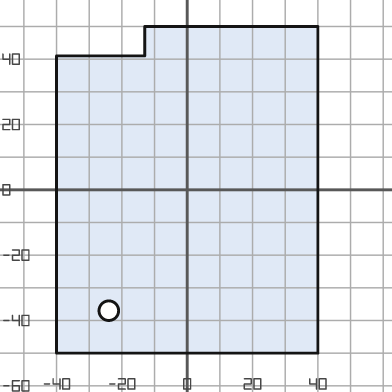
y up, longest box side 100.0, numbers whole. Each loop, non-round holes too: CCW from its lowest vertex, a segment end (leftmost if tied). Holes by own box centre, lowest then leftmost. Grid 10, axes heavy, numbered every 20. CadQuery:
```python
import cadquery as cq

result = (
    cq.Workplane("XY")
    .moveTo(-40.0, -50.0)
    .lineTo(40.0, -50.0)
    .lineTo(40.0, 50.0)
    .lineTo(-13.0, 50.0)
    .lineTo(-13.0, 41.0)
    .lineTo(-40.0, 41.0)
    .close()
    .moveTo(-24.0, -37.0)
    .circle(3.0)
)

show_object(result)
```